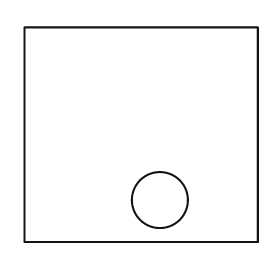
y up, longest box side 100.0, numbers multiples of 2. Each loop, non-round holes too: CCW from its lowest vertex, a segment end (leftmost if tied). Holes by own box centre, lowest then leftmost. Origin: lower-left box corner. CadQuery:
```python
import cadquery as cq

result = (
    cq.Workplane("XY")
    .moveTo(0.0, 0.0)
    .lineTo(100.0, 0.0)
    .lineTo(100.0, 92.0)
    .lineTo(0.0, 92.0)
    .close()
    .moveTo(58.0, 18.0)
    .circle(12.0)
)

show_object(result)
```